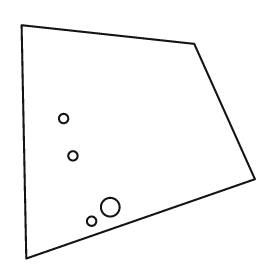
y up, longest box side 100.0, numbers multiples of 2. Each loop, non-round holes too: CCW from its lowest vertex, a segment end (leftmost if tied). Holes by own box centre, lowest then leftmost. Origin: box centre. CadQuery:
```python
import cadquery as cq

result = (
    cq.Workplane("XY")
    .moveTo(-48.0, -50.0)
    .lineTo(50.0, -16.0)
    .lineTo(24.0, 42.0)
    .lineTo(-50.0, 50.0)
    .close()
    .moveTo(-20.0, -34.0)
    .circle(2.0)
    .moveTo(-12.0, -28.0)
    .circle(4.0)
    .moveTo(-28.0, -6.0)
    .circle(2.0)
    .moveTo(-32.0, 10.0)
    .circle(2.0)
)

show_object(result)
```